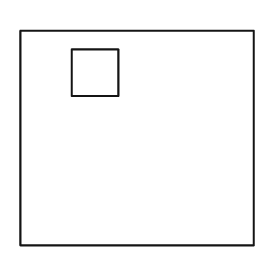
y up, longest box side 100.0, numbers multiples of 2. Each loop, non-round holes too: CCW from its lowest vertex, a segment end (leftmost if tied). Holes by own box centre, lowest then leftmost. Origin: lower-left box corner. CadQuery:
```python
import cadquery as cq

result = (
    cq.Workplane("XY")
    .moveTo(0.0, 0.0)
    .lineTo(100.0, 0.0)
    .lineTo(100.0, 92.0)
    .lineTo(0.0, 92.0)
    .close()
    .moveTo(22.0, 64.0)
    .lineTo(42.0, 64.0)
    .lineTo(42.0, 84.0)
    .lineTo(22.0, 84.0)
    .close()
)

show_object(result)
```